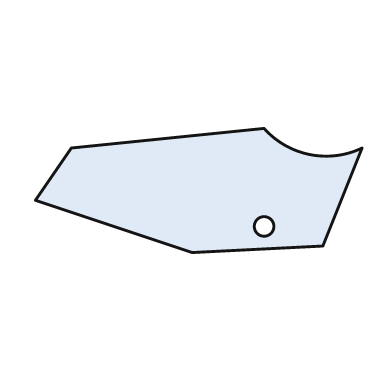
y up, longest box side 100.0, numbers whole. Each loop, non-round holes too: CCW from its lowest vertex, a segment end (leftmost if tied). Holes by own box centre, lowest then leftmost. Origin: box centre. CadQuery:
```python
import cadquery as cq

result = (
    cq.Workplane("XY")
    .moveTo(-2.0, -19.0)
    .lineTo(38.0, -17.0)
    .lineTo(50.0, 13.0)
    .threePointArc((34.0, 11.0), (20.0, 19.0))
    .lineTo(-39.0, 13.0)
    .lineTo(-50.0, -3.0)
    .close()
    .moveTo(20.0, -11.0)
    .circle(3.0)
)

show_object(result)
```